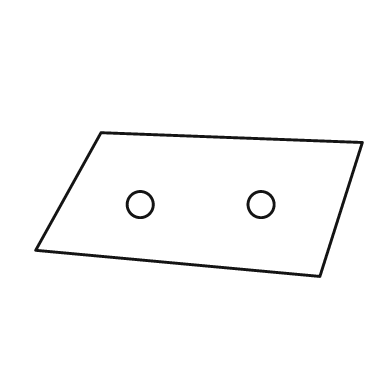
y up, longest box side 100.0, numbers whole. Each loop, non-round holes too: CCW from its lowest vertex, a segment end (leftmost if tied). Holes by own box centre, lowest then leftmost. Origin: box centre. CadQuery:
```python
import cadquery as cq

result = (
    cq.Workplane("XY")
    .moveTo(37.0, -22.0)
    .lineTo(50.0, 19.0)
    .lineTo(-30.0, 22.0)
    .lineTo(-50.0, -14.0)
    .close()
    .moveTo(-18.0, 0.0)
    .circle(4.0)
    .moveTo(19.0, 0.0)
    .circle(4.0)
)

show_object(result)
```